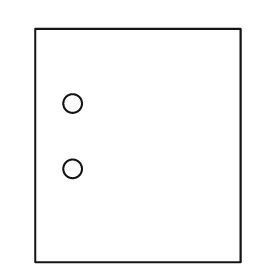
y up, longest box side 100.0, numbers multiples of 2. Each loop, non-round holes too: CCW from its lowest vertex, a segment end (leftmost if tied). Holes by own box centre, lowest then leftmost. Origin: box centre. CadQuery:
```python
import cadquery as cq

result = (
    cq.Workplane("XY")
    .moveTo(-44.0, -50.0)
    .lineTo(44.0, -50.0)
    .lineTo(44.0, 50.0)
    .lineTo(-44.0, 50.0)
    .close()
    .moveTo(-28.0, -10.0)
    .circle(4.0)
    .moveTo(-28.0, 18.0)
    .circle(4.0)
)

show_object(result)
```